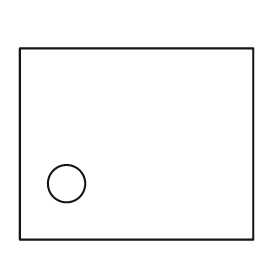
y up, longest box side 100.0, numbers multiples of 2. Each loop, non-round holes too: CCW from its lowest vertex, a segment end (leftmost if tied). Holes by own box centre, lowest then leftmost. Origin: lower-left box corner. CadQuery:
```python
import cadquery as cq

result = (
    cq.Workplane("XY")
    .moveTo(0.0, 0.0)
    .lineTo(100.0, 0.0)
    .lineTo(100.0, 82.0)
    .lineTo(0.0, 82.0)
    .close()
    .moveTo(20.0, 24.0)
    .circle(8.0)
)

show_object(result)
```